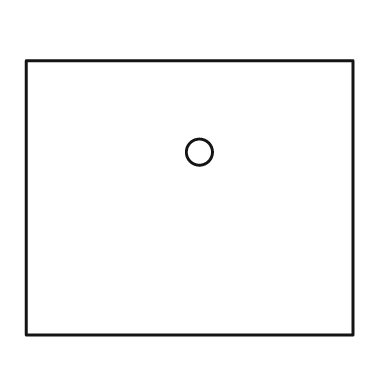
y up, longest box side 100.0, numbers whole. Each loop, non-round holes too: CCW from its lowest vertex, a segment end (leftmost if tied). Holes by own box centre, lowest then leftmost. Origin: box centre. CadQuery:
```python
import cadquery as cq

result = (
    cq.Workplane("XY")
    .moveTo(-50.0, -42.0)
    .lineTo(50.0, -42.0)
    .lineTo(50.0, 42.0)
    .lineTo(-50.0, 42.0)
    .close()
    .moveTo(3.0, 14.0)
    .circle(4.0)
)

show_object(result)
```